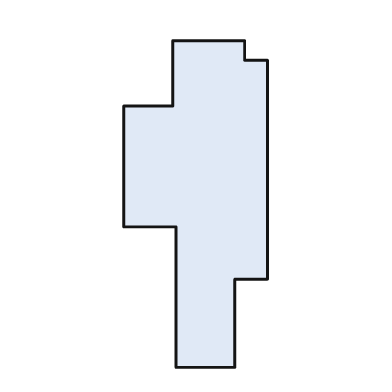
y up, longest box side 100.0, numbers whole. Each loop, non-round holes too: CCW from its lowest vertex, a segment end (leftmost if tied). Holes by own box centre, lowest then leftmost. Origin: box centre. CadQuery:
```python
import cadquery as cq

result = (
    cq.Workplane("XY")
    .moveTo(-6.0, -50.0)
    .lineTo(12.0, -50.0)
    .lineTo(12.0, -23.0)
    .lineTo(22.0, -23.0)
    .lineTo(22.0, 44.0)
    .lineTo(15.0, 44.0)
    .lineTo(15.0, 50.0)
    .lineTo(-7.0, 50.0)
    .lineTo(-7.0, 30.0)
    .lineTo(-22.0, 30.0)
    .lineTo(-22.0, -7.0)
    .lineTo(-6.0, -7.0)
    .close()
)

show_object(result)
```